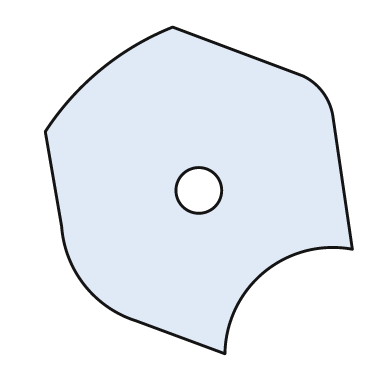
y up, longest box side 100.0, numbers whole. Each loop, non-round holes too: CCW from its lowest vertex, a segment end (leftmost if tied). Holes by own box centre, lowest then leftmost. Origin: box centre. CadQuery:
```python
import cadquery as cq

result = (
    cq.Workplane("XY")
    .moveTo(8.0, -50.0)
    .threePointArc((20.0, -25.0), (47.0, -18.0))
    .lineTo(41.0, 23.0)
    .threePointArc((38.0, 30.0), (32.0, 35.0))
    .lineTo(-8.0, 50.0)
    .threePointArc((-30.0, 37.0), (-47.0, 18.0))
    .lineTo(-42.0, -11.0)
    .threePointArc((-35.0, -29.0), (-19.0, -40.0))
    .close()
    .moveTo(0.0, 0.0)
    .circle(7.0)
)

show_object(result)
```